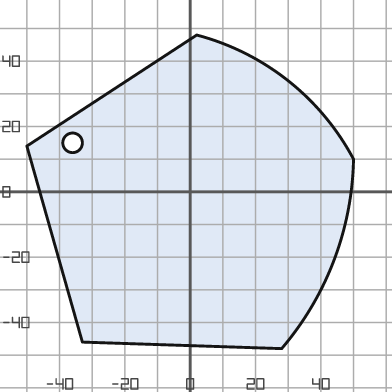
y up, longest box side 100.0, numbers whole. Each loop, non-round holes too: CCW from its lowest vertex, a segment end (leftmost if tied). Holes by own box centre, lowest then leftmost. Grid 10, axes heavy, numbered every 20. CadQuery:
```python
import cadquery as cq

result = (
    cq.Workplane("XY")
    .moveTo(28.0, -48.0)
    .threePointArc((44.0, -21.0), (50.0, 10.0))
    .threePointArc((30.0, 34.0), (2.0, 48.0))
    .lineTo(-50.0, 14.0)
    .lineTo(-33.0, -46.0)
    .close()
    .moveTo(-36.0, 15.0)
    .circle(3.0)
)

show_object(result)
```